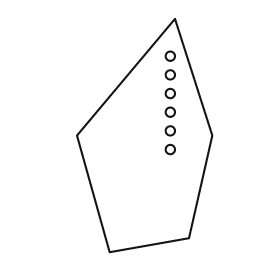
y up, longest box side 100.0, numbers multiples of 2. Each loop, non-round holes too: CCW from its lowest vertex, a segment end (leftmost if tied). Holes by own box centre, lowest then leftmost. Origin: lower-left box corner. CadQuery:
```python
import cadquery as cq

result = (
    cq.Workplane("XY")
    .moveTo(14.0, 0.0)
    .lineTo(48.0, 6.0)
    .lineTo(58.0, 50.0)
    .lineTo(42.0, 100.0)
    .lineTo(0.0, 50.0)
    .close()
    .moveTo(40.0, 44.0)
    .circle(2.0)
    .moveTo(40.0, 52.0)
    .circle(2.0)
    .moveTo(40.0, 60.0)
    .circle(2.0)
    .moveTo(40.0, 68.0)
    .circle(2.0)
    .moveTo(40.0, 76.0)
    .circle(2.0)
    .moveTo(40.0, 84.0)
    .circle(2.0)
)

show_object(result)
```